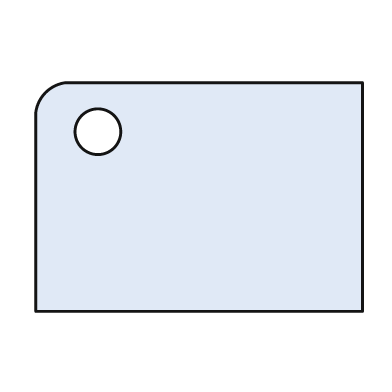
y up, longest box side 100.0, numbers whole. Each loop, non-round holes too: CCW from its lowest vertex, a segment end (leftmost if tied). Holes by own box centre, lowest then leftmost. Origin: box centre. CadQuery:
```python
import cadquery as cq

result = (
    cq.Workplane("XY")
    .moveTo(-50.0, -35.0)
    .lineTo(50.0, -35.0)
    .lineTo(50.0, 35.0)
    .lineTo(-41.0, 35.0)
    .threePointArc((-47.0, 32.0), (-50.0, 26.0))
    .close()
    .moveTo(-31.0, 20.0)
    .circle(7.0)
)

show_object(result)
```